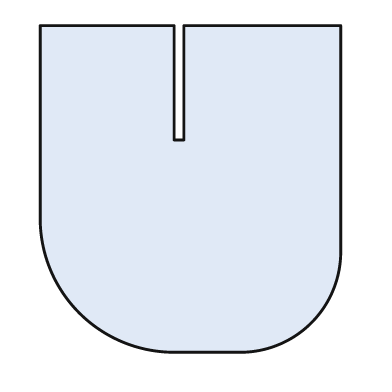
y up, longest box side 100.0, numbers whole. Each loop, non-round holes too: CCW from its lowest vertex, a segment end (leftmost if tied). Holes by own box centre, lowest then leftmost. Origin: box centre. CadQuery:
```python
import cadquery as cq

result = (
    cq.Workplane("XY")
    .moveTo(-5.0, -50.0)
    .lineTo(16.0, -50.0)
    .threePointArc((37.0, -41.0), (46.0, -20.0))
    .lineTo(46.0, 50.0)
    .lineTo(-2.0, 50.0)
    .lineTo(-2.0, 15.0)
    .lineTo(-5.0, 15.0)
    .lineTo(-5.0, 50.0)
    .lineTo(-46.0, 50.0)
    .lineTo(-46.0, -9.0)
    .threePointArc((-34.0, -38.0), (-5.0, -50.0))
    .close()
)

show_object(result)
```